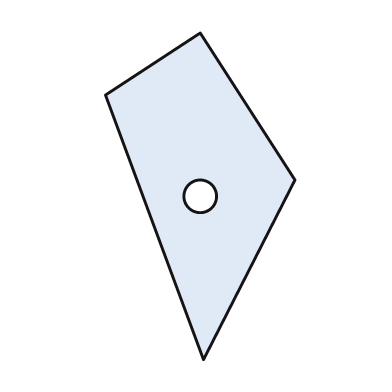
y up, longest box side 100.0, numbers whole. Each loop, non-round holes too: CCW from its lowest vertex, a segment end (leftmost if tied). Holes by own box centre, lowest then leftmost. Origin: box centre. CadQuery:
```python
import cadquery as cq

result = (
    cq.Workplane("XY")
    .moveTo(1.0, -50.0)
    .lineTo(29.0, 5.0)
    .lineTo(0.0, 50.0)
    .lineTo(-29.0, 31.0)
    .close()
    .moveTo(0.0, 0.0)
    .circle(5.0)
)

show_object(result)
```